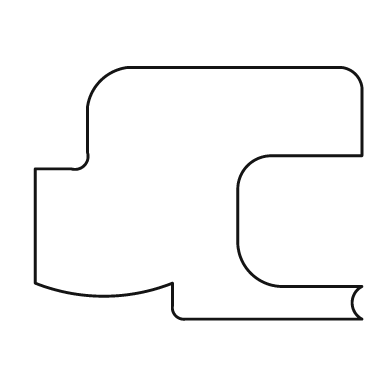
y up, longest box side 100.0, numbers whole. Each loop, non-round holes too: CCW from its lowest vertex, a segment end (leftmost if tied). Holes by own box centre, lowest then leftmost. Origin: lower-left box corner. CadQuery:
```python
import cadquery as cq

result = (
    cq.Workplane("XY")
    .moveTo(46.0, 0.0)
    .lineTo(100.0, 0.0)
    .threePointArc((97.0, 5.0), (100.0, 10.0))
    .lineTo(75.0, 10.0)
    .threePointArc((66.0, 14.0), (62.0, 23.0))
    .lineTo(62.0, 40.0)
    .threePointArc((65.0, 47.0), (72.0, 50.0))
    .lineTo(100.0, 50.0)
    .lineTo(100.0, 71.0)
    .threePointArc((98.0, 75.0), (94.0, 77.0))
    .lineTo(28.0, 77.0)
    .threePointArc((20.0, 73.0), (16.0, 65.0))
    .lineTo(16.0, 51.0)
    .threePointArc((15.0, 47.0), (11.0, 46.0))
    .lineTo(0.0, 46.0)
    .lineTo(0.0, 11.0)
    .threePointArc((21.0, 7.0), (42.0, 11.0))
    .lineTo(42.0, 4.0)
    .threePointArc((43.0, 1.0), (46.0, 0.0))
    .close()
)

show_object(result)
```